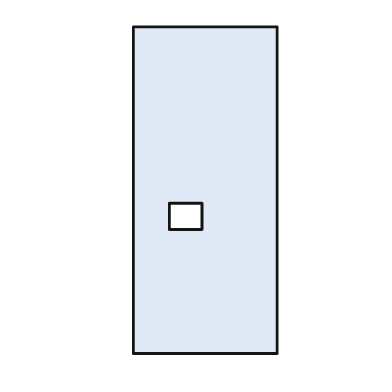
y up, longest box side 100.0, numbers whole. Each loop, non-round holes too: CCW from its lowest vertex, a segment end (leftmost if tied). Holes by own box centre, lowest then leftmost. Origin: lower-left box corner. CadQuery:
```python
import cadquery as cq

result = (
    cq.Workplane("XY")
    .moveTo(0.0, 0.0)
    .lineTo(44.0, 0.0)
    .lineTo(44.0, 100.0)
    .lineTo(0.0, 100.0)
    .close()
    .moveTo(11.0, 38.0)
    .lineTo(21.0, 38.0)
    .lineTo(21.0, 46.0)
    .lineTo(11.0, 46.0)
    .close()
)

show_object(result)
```